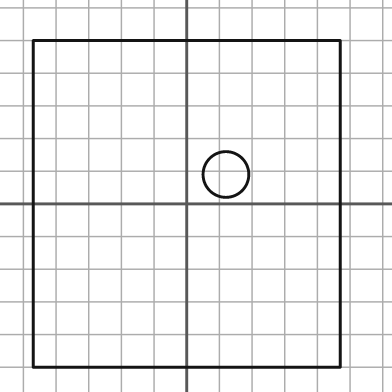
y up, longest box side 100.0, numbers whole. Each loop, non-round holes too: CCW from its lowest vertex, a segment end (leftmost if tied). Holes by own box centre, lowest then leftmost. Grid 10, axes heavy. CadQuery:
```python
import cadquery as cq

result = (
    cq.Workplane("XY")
    .moveTo(-47.0, -50.0)
    .lineTo(47.0, -50.0)
    .lineTo(47.0, 50.0)
    .lineTo(-47.0, 50.0)
    .close()
    .moveTo(12.0, 9.0)
    .circle(7.0)
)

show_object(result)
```